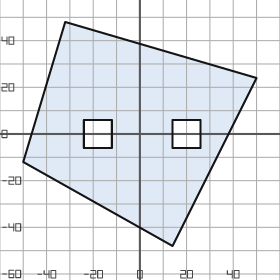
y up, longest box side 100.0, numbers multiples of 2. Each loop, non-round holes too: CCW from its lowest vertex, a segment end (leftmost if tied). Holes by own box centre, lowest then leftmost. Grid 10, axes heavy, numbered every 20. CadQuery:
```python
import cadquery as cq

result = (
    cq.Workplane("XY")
    .moveTo(14.0, -48.0)
    .lineTo(50.0, 24.0)
    .lineTo(-32.0, 48.0)
    .lineTo(-50.0, -12.0)
    .close()
    .moveTo(-24.0, -6.0)
    .lineTo(-12.0, -6.0)
    .lineTo(-12.0, 6.0)
    .lineTo(-24.0, 6.0)
    .close()
    .moveTo(14.0, -6.0)
    .lineTo(26.0, -6.0)
    .lineTo(26.0, 6.0)
    .lineTo(14.0, 6.0)
    .close()
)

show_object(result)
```